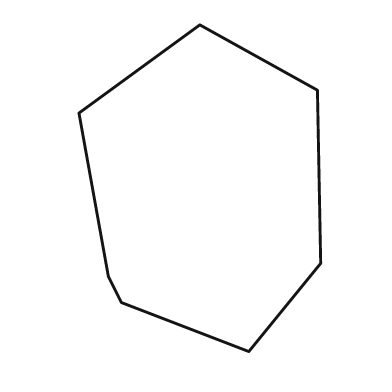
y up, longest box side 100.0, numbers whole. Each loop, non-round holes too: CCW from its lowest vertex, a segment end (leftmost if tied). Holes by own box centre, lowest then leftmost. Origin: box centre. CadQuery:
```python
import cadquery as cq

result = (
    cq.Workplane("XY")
    .moveTo(15.0, -50.0)
    .lineTo(37.0, -23.0)
    .lineTo(36.0, 30.0)
    .lineTo(0.0, 50.0)
    .lineTo(-37.0, 23.0)
    .lineTo(-28.0, -27.0)
    .lineTo(-24.0, -35.0)
    .close()
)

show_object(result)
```